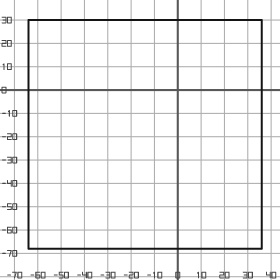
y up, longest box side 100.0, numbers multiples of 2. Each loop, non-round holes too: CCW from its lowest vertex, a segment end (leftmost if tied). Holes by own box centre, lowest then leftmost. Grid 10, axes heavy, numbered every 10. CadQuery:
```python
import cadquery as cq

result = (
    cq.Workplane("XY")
    .moveTo(-64.0, -68.0)
    .lineTo(36.0, -68.0)
    .lineTo(36.0, 30.0)
    .lineTo(-64.0, 30.0)
    .close()
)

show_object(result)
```